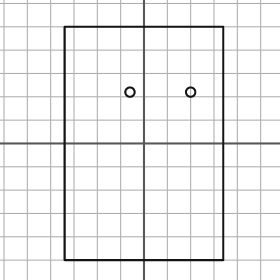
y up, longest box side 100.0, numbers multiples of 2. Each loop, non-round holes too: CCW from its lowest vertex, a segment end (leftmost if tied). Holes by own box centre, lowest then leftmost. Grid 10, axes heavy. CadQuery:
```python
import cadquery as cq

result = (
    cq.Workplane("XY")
    .moveTo(-34.0, -50.0)
    .lineTo(34.0, -50.0)
    .lineTo(34.0, 50.0)
    .lineTo(-34.0, 50.0)
    .close()
    .moveTo(-6.0, 22.0)
    .circle(2.0)
    .moveTo(20.0, 22.0)
    .circle(2.0)
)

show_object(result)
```